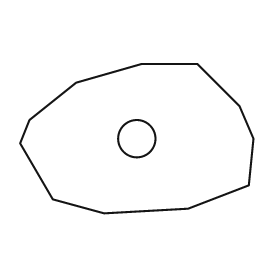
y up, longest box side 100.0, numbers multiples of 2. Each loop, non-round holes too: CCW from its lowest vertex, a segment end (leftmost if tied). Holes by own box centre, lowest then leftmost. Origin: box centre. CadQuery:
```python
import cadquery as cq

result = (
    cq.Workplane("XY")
    .moveTo(-14.0, -32.0)
    .lineTo(22.0, -30.0)
    .lineTo(48.0, -20.0)
    .lineTo(50.0, 0.0)
    .lineTo(44.0, 14.0)
    .lineTo(26.0, 32.0)
    .lineTo(2.0, 32.0)
    .lineTo(-26.0, 24.0)
    .lineTo(-46.0, 8.0)
    .lineTo(-50.0, -2.0)
    .lineTo(-36.0, -26.0)
    .close()
    .moveTo(0.0, 0.0)
    .circle(8.0)
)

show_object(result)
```